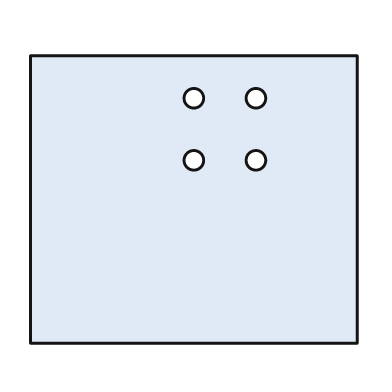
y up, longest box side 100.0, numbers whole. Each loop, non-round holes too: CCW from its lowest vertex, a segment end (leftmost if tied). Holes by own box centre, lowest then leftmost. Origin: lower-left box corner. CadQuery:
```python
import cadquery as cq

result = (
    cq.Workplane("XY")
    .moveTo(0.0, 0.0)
    .lineTo(100.0, 0.0)
    .lineTo(100.0, 88.0)
    .lineTo(0.0, 88.0)
    .close()
    .moveTo(50.0, 56.0)
    .circle(3.0)
    .moveTo(69.0, 56.0)
    .circle(3.0)
    .moveTo(50.0, 75.0)
    .circle(3.0)
    .moveTo(69.0, 75.0)
    .circle(3.0)
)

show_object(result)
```